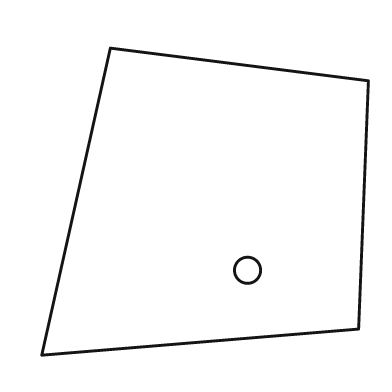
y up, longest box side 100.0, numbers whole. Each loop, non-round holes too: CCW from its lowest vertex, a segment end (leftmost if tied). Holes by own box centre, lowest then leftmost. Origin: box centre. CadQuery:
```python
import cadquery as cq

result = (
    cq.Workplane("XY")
    .moveTo(-50.0, -47.0)
    .lineTo(47.0, -39.0)
    .lineTo(50.0, 37.0)
    .lineTo(-29.0, 47.0)
    .close()
    .moveTo(13.0, -21.0)
    .circle(4.0)
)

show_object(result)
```